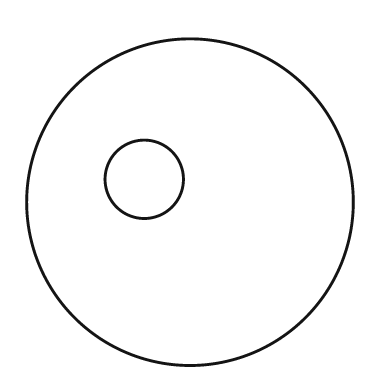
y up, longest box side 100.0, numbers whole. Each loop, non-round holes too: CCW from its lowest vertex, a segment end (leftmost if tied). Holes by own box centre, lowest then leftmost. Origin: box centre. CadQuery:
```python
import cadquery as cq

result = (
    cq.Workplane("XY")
    .moveTo(0.0, 0.0)
    .circle(50.0)
    .moveTo(-14.0, 7.0)
    .circle(12.0)
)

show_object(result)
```